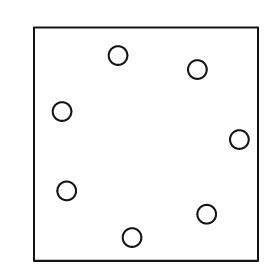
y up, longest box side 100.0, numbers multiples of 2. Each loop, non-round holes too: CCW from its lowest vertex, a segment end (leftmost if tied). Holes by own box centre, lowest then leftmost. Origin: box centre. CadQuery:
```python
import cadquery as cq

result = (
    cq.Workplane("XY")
    .moveTo(-48.0, -50.0)
    .lineTo(48.0, -50.0)
    .lineTo(48.0, 50.0)
    .lineTo(-48.0, 50.0)
    .close()
    .moveTo(-6.0, -40.0)
    .circle(4.0)
    .moveTo(26.0, -30.0)
    .circle(4.0)
    .moveTo(-34.0, -20.0)
    .circle(4.0)
    .moveTo(40.0, 2.0)
    .circle(4.0)
    .moveTo(-36.0, 14.0)
    .circle(4.0)
    .moveTo(22.0, 32.0)
    .circle(4.0)
    .moveTo(-12.0, 38.0)
    .circle(4.0)
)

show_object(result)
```